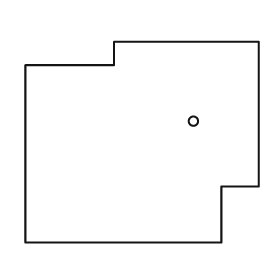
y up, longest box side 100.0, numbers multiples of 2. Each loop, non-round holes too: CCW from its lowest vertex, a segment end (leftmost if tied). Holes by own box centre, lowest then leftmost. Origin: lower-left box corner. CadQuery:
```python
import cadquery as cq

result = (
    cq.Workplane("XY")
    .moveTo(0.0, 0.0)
    .lineTo(84.0, 0.0)
    .lineTo(84.0, 24.0)
    .lineTo(100.0, 24.0)
    .lineTo(100.0, 86.0)
    .lineTo(38.0, 86.0)
    .lineTo(38.0, 76.0)
    .lineTo(0.0, 76.0)
    .close()
    .moveTo(72.0, 52.0)
    .circle(2.0)
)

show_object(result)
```